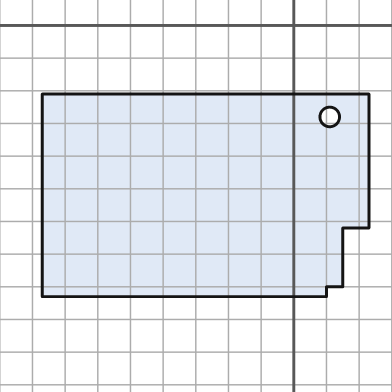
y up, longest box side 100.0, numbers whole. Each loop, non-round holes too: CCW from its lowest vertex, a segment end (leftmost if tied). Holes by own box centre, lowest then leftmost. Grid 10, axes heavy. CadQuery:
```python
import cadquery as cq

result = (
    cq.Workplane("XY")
    .moveTo(-77.0, -83.0)
    .lineTo(10.0, -83.0)
    .lineTo(10.0, -80.0)
    .lineTo(15.0, -80.0)
    .lineTo(15.0, -62.0)
    .lineTo(23.0, -62.0)
    .lineTo(23.0, -21.0)
    .lineTo(-77.0, -21.0)
    .close()
    .moveTo(11.0, -28.0)
    .circle(3.0)
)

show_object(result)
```